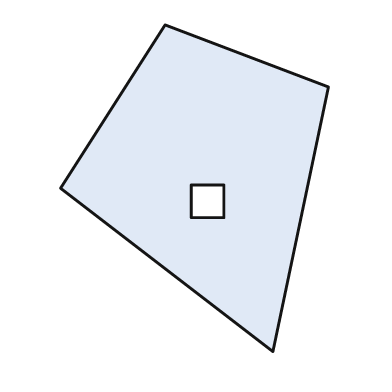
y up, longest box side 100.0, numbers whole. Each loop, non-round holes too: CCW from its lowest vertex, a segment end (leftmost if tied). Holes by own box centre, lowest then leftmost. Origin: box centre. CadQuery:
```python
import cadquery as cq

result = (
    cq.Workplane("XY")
    .moveTo(24.0, -50.0)
    .lineTo(41.0, 31.0)
    .lineTo(-9.0, 50.0)
    .lineTo(-41.0, 0.0)
    .close()
    .moveTo(-1.0, -9.0)
    .lineTo(9.0, -9.0)
    .lineTo(9.0, 1.0)
    .lineTo(-1.0, 1.0)
    .close()
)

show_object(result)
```